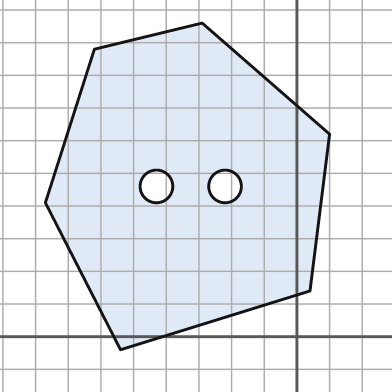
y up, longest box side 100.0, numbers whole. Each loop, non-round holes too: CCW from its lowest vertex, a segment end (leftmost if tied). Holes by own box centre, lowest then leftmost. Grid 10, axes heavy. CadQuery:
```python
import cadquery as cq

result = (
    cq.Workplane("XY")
    .moveTo(-54.0, -4.0)
    .lineTo(4.0, 14.0)
    .lineTo(10.0, 62.0)
    .lineTo(-29.0, 96.0)
    .lineTo(-62.0, 88.0)
    .lineTo(-77.0, 41.0)
    .close()
    .moveTo(-43.0, 46.0)
    .circle(5.0)
    .moveTo(-22.0, 46.0)
    .circle(5.0)
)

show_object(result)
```